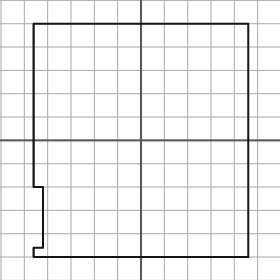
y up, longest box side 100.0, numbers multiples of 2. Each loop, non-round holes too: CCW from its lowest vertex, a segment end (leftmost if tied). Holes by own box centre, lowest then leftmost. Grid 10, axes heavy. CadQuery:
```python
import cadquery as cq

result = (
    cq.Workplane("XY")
    .moveTo(-46.0, -50.0)
    .lineTo(46.0, -50.0)
    .lineTo(46.0, 50.0)
    .lineTo(-46.0, 50.0)
    .lineTo(-46.0, -20.0)
    .lineTo(-42.0, -20.0)
    .lineTo(-42.0, -46.0)
    .lineTo(-46.0, -46.0)
    .close()
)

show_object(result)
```